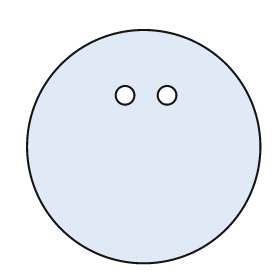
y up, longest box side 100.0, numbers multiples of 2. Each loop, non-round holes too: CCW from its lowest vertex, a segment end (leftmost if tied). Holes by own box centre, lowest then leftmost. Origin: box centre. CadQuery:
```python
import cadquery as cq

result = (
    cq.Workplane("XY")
    .moveTo(0.0, 0.0)
    .circle(50.0)
    .moveTo(-8.0, 22.0)
    .circle(4.0)
    .moveTo(10.0, 22.0)
    .circle(4.0)
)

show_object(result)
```